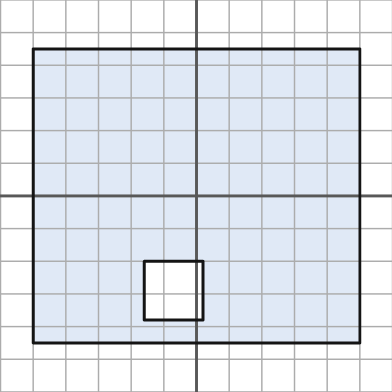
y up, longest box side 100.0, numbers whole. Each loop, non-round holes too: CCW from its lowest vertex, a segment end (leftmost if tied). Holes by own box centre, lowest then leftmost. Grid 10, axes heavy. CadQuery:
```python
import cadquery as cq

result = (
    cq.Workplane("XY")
    .moveTo(-50.0, -45.0)
    .lineTo(50.0, -45.0)
    .lineTo(50.0, 45.0)
    .lineTo(-50.0, 45.0)
    .close()
    .moveTo(-16.0, -38.0)
    .lineTo(2.0, -38.0)
    .lineTo(2.0, -20.0)
    .lineTo(-16.0, -20.0)
    .close()
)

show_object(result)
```